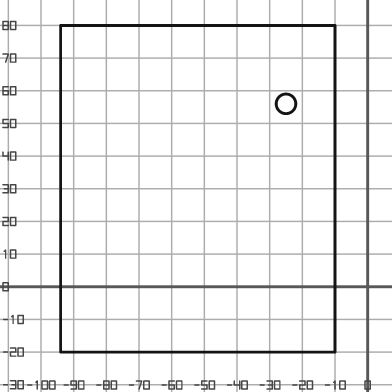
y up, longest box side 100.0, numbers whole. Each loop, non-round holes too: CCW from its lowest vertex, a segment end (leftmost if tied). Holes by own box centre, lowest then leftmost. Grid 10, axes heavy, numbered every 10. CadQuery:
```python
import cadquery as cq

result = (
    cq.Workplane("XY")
    .moveTo(-94.0, -20.0)
    .lineTo(-10.0, -20.0)
    .lineTo(-10.0, 80.0)
    .lineTo(-94.0, 80.0)
    .close()
    .moveTo(-25.0, 56.0)
    .circle(3.0)
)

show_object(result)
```